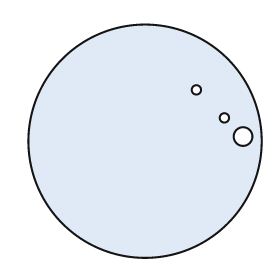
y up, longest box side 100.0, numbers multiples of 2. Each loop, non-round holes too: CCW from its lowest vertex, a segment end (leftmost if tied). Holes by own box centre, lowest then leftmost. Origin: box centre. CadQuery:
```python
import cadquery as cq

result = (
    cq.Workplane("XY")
    .moveTo(0.0, 0.0)
    .circle(50.0)
    .moveTo(42.0, 2.0)
    .circle(4.0)
    .moveTo(34.0, 10.0)
    .circle(2.0)
    .moveTo(22.0, 22.0)
    .circle(2.0)
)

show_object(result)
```